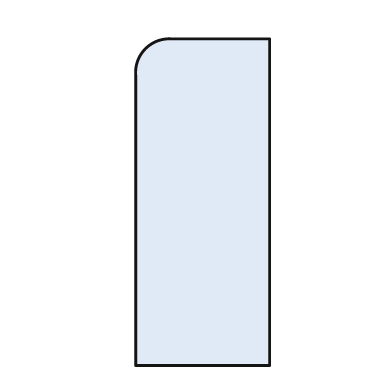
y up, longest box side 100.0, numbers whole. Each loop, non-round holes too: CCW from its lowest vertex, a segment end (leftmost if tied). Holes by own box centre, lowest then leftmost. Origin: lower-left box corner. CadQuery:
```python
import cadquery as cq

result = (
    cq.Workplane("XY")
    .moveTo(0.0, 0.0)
    .lineTo(41.0, 0.0)
    .lineTo(41.0, 100.0)
    .lineTo(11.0, 100.0)
    .threePointArc((3.0, 97.0), (0.0, 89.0))
    .close()
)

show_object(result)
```